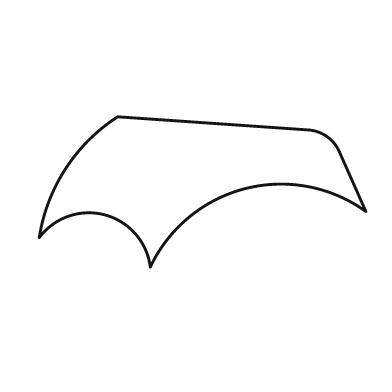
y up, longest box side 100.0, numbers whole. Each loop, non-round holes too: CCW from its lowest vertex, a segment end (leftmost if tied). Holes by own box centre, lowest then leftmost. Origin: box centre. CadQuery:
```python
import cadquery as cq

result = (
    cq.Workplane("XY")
    .moveTo(-16.0, -23.0)
    .threePointArc((13.0, 1.0), (50.0, -6.0))
    .lineTo(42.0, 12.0)
    .threePointArc((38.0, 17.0), (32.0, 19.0))
    .lineTo(-26.0, 23.0)
    .threePointArc((-42.0, 7.0), (-50.0, -14.0))
    .threePointArc((-30.0, -7.0), (-16.0, -23.0))
    .close()
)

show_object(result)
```